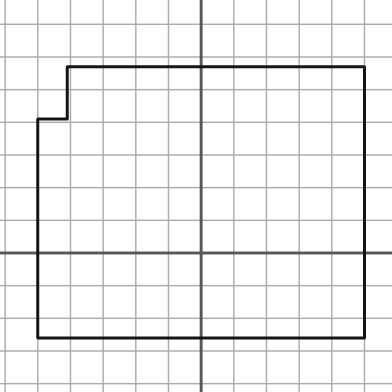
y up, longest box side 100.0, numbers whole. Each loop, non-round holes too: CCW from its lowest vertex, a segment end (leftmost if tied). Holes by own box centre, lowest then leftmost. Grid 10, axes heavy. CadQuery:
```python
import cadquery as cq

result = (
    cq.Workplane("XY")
    .moveTo(-50.0, -26.0)
    .lineTo(50.0, -26.0)
    .lineTo(50.0, 57.0)
    .lineTo(-41.0, 57.0)
    .lineTo(-41.0, 41.0)
    .lineTo(-50.0, 41.0)
    .close()
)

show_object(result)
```